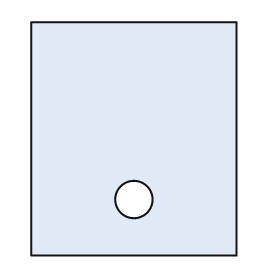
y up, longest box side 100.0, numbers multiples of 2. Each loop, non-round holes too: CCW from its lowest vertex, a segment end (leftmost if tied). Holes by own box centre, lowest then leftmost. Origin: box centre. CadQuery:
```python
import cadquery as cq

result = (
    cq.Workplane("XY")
    .moveTo(-44.0, -50.0)
    .lineTo(44.0, -50.0)
    .lineTo(44.0, 50.0)
    .lineTo(-44.0, 50.0)
    .close()
    .moveTo(0.0, -26.0)
    .circle(8.0)
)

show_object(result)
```